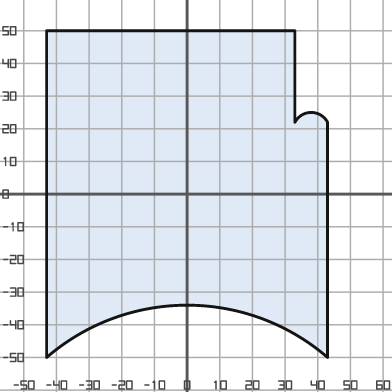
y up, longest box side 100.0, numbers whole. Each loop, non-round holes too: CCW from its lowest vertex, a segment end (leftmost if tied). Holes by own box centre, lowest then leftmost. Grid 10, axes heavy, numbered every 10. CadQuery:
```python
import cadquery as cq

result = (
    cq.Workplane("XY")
    .moveTo(-43.0, -50.0)
    .threePointArc((0.0, -34.0), (43.0, -50.0))
    .lineTo(43.0, 22.0)
    .threePointArc((38.0, 25.0), (33.0, 22.0))
    .lineTo(33.0, 50.0)
    .lineTo(-43.0, 50.0)
    .close()
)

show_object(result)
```